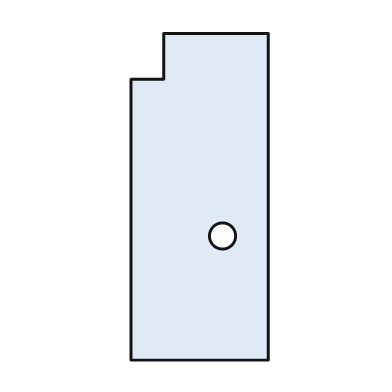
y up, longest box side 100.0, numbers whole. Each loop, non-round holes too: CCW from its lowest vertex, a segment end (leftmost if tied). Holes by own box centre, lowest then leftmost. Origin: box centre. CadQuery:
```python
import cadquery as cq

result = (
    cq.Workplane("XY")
    .moveTo(-21.0, -50.0)
    .lineTo(21.0, -50.0)
    .lineTo(21.0, 50.0)
    .lineTo(-11.0, 50.0)
    .lineTo(-11.0, 36.0)
    .lineTo(-21.0, 36.0)
    .close()
    .moveTo(7.0, -12.0)
    .circle(4.0)
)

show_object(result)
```